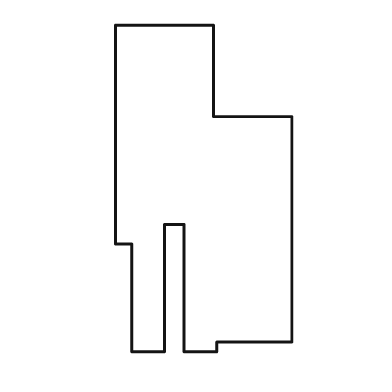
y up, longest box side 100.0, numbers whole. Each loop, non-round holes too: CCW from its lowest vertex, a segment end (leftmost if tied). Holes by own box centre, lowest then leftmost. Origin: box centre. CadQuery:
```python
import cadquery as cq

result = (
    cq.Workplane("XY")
    .moveTo(-22.0, -50.0)
    .lineTo(-12.0, -50.0)
    .lineTo(-12.0, -11.0)
    .lineTo(-6.0, -11.0)
    .lineTo(-6.0, -50.0)
    .lineTo(4.0, -50.0)
    .lineTo(4.0, -47.0)
    .lineTo(27.0, -47.0)
    .lineTo(27.0, 22.0)
    .lineTo(3.0, 22.0)
    .lineTo(3.0, 50.0)
    .lineTo(-27.0, 50.0)
    .lineTo(-27.0, -17.0)
    .lineTo(-22.0, -17.0)
    .close()
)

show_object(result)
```